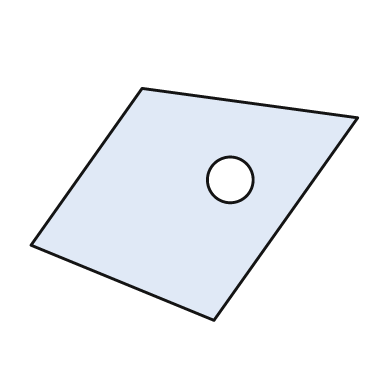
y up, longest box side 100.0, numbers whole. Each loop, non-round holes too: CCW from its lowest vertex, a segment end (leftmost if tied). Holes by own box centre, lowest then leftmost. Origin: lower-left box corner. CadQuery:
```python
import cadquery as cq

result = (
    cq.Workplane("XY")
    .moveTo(56.0, 0.0)
    .lineTo(100.0, 62.0)
    .lineTo(34.0, 71.0)
    .lineTo(0.0, 23.0)
    .close()
    .moveTo(61.0, 43.0)
    .circle(7.0)
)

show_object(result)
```